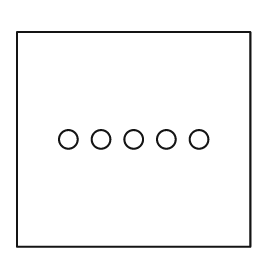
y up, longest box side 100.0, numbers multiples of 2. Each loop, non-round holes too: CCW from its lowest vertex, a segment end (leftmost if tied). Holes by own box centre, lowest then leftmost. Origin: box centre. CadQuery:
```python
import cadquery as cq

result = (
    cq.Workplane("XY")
    .moveTo(-50.0, -46.0)
    .lineTo(50.0, -46.0)
    .lineTo(50.0, 46.0)
    .lineTo(-50.0, 46.0)
    .close()
    .moveTo(-28.0, 0.0)
    .circle(4.0)
    .moveTo(-14.0, 0.0)
    .circle(4.0)
    .moveTo(0.0, 0.0)
    .circle(4.0)
    .moveTo(14.0, 0.0)
    .circle(4.0)
    .moveTo(28.0, 0.0)
    .circle(4.0)
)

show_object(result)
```